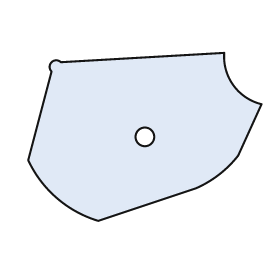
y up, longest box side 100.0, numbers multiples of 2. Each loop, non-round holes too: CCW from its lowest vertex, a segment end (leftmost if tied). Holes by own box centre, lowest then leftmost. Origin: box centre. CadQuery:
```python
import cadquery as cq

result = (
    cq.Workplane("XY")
    .moveTo(-20.0, -36.0)
    .lineTo(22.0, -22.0)
    .threePointArc((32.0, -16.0), (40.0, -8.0))
    .lineTo(50.0, 14.0)
    .threePointArc((38.0, 22.0), (34.0, 36.0))
    .lineTo(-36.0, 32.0)
    .threePointArc((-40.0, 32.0), (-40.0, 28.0))
    .lineTo(-50.0, -10.0)
    .threePointArc((-38.0, -26.0), (-20.0, -36.0))
    .close()
    .moveTo(0.0, 0.0)
    .circle(4.0)
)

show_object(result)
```